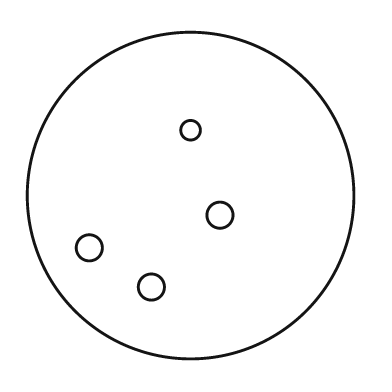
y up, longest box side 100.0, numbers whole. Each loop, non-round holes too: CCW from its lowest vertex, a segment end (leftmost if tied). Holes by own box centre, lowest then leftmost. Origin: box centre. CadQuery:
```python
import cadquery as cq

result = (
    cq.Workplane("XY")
    .moveTo(0.0, 0.0)
    .circle(50.0)
    .moveTo(-12.0, -28.0)
    .circle(4.0)
    .moveTo(-31.0, -16.0)
    .circle(4.0)
    .moveTo(9.0, -6.0)
    .circle(4.0)
    .moveTo(0.0, 20.0)
    .circle(3.0)
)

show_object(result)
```